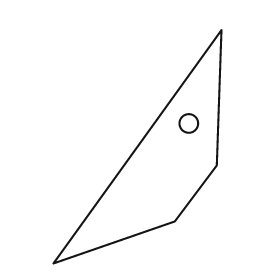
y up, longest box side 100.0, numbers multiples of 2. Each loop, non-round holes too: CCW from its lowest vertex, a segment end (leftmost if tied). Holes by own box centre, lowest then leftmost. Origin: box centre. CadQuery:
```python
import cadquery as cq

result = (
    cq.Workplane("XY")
    .moveTo(-36.0, -50.0)
    .lineTo(16.0, -32.0)
    .lineTo(34.0, -8.0)
    .lineTo(36.0, 50.0)
    .close()
    .moveTo(22.0, 10.0)
    .circle(4.0)
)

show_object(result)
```